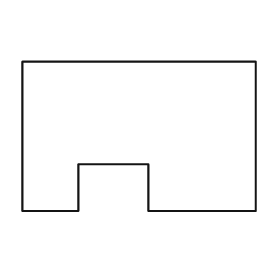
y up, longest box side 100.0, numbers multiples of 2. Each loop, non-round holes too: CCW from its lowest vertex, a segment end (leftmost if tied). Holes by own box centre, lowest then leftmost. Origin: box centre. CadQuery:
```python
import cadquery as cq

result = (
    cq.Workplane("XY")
    .moveTo(-50.0, -32.0)
    .lineTo(-26.0, -32.0)
    .lineTo(-26.0, -12.0)
    .lineTo(4.0, -12.0)
    .lineTo(4.0, -32.0)
    .lineTo(50.0, -32.0)
    .lineTo(50.0, 32.0)
    .lineTo(-50.0, 32.0)
    .close()
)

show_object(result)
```